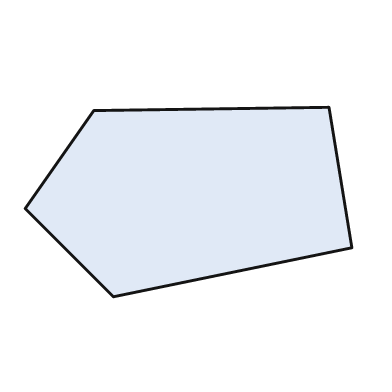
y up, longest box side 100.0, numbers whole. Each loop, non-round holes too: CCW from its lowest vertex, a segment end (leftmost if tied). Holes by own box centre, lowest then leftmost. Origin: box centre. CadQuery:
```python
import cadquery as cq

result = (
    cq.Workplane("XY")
    .moveTo(-23.0, -29.0)
    .lineTo(50.0, -14.0)
    .lineTo(43.0, 29.0)
    .lineTo(-29.0, 28.0)
    .lineTo(-50.0, -2.0)
    .close()
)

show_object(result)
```